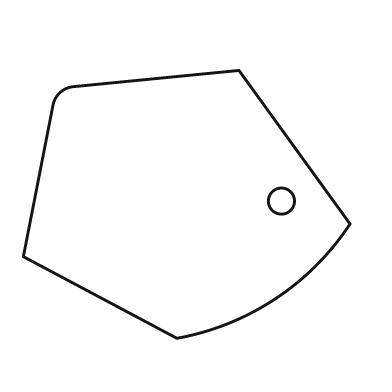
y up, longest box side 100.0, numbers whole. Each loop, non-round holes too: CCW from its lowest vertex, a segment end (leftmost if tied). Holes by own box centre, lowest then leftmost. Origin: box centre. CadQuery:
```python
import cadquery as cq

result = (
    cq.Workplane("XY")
    .moveTo(-3.0, -41.0)
    .threePointArc((27.0, -29.0), (50.0, -6.0))
    .lineTo(16.0, 41.0)
    .lineTo(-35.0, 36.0)
    .threePointArc((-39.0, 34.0), (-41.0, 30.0))
    .lineTo(-50.0, -16.0)
    .close()
    .moveTo(29.0, 1.0)
    .circle(4.0)
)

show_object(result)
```